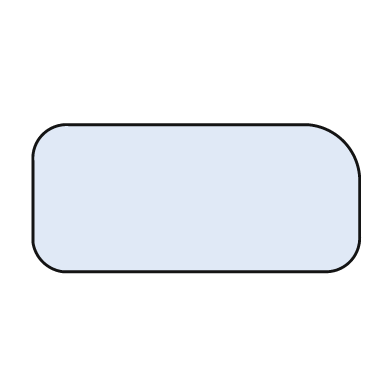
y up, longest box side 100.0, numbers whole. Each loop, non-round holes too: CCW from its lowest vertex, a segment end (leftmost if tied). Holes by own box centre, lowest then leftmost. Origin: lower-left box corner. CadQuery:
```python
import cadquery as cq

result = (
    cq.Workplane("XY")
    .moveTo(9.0, 0.0)
    .lineTo(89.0, 0.0)
    .threePointArc((97.0, 3.0), (100.0, 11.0))
    .lineTo(100.0, 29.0)
    .threePointArc((95.0, 40.0), (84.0, 45.0))
    .lineTo(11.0, 45.0)
    .threePointArc((3.0, 42.0), (0.0, 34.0))
    .lineTo(0.0, 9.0)
    .threePointArc((3.0, 3.0), (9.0, 0.0))
    .close()
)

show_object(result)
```